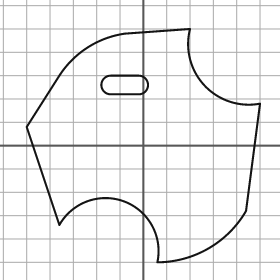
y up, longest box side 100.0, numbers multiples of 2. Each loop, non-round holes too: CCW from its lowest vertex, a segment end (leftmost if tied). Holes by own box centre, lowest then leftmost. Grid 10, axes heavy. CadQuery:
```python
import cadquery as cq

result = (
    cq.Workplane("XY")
    .moveTo(6.0, -50.0)
    .threePointArc((28.0, -44.0), (44.0, -28.0))
    .lineTo(50.0, 18.0)
    .threePointArc((26.0, 26.0), (20.0, 50.0))
    .lineTo(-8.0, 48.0)
    .threePointArc((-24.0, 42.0), (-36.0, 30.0))
    .lineTo(-50.0, 8.0)
    .lineTo(-36.0, -34.0)
    .threePointArc((-8.0, -24.0), (6.0, -50.0))
    .close()
    .moveTo(-14.0, 22.0)
    .lineTo(-2.0, 22.0)
    .threePointArc((2.0, 26.0), (-2.0, 30.0))
    .lineTo(-14.0, 30.0)
    .threePointArc((-18.0, 26.0), (-14.0, 22.0))
    .close()
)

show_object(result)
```